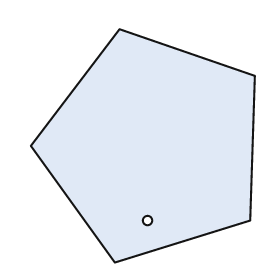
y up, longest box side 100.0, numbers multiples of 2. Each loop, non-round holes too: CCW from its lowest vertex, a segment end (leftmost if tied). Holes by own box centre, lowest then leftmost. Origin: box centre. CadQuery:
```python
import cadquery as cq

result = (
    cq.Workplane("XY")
    .moveTo(-12.0, -50.0)
    .lineTo(46.0, -32.0)
    .lineTo(48.0, 30.0)
    .lineTo(-10.0, 50.0)
    .lineTo(-48.0, 0.0)
    .close()
    .moveTo(2.0, -32.0)
    .circle(2.0)
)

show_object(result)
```